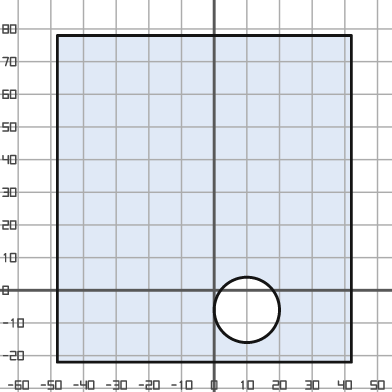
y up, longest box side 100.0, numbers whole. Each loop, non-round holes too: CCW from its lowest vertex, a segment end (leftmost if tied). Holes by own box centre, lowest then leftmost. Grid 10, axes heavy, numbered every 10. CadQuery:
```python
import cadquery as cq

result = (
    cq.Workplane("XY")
    .moveTo(-48.0, -22.0)
    .lineTo(42.0, -22.0)
    .lineTo(42.0, 78.0)
    .lineTo(-48.0, 78.0)
    .close()
    .moveTo(10.0, -6.0)
    .circle(10.0)
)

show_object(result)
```